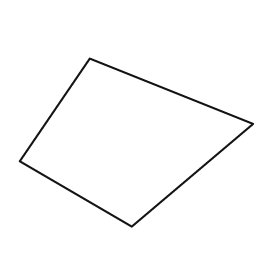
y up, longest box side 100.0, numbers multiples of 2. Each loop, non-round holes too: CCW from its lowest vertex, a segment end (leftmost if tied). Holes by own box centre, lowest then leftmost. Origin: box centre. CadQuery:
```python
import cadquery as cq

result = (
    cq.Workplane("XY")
    .moveTo(-2.0, -36.0)
    .lineTo(50.0, 8.0)
    .lineTo(-20.0, 36.0)
    .lineTo(-50.0, -8.0)
    .close()
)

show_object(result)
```